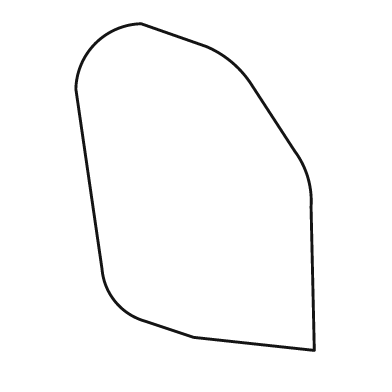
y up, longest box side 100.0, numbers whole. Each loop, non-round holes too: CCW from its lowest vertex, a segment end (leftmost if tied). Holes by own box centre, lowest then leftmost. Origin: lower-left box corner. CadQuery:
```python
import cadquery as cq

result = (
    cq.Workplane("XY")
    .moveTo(73.0, 0.0)
    .lineTo(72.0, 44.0)
    .threePointArc((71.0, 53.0), (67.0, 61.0))
    .lineTo(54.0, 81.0)
    .threePointArc((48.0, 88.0), (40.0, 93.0))
    .lineTo(20.0, 100.0)
    .threePointArc((6.0, 94.0), (0.0, 80.0))
    .lineTo(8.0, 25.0)
    .threePointArc((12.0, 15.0), (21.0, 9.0))
    .lineTo(36.0, 4.0)
    .close()
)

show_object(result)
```